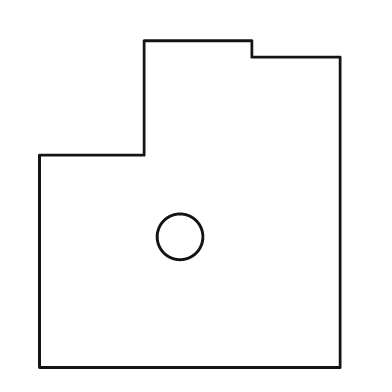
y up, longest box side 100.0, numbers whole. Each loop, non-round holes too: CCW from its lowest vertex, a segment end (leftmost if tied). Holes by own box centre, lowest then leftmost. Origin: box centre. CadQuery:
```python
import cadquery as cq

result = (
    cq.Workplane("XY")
    .moveTo(-46.0, -50.0)
    .lineTo(46.0, -50.0)
    .lineTo(46.0, 45.0)
    .lineTo(19.0, 45.0)
    .lineTo(19.0, 50.0)
    .lineTo(-14.0, 50.0)
    .lineTo(-14.0, 15.0)
    .lineTo(-46.0, 15.0)
    .close()
    .moveTo(-3.0, -10.0)
    .circle(7.0)
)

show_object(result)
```